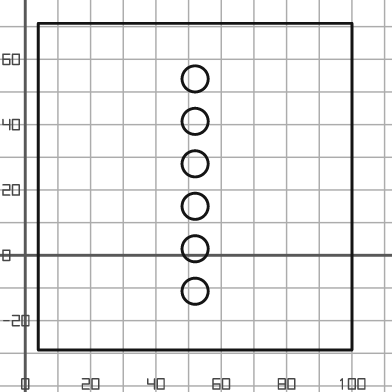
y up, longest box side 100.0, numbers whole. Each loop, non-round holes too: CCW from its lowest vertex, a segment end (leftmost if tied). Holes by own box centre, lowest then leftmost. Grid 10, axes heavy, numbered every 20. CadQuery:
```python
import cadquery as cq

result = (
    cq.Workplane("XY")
    .moveTo(4.0, -29.0)
    .lineTo(100.0, -29.0)
    .lineTo(100.0, 71.0)
    .lineTo(4.0, 71.0)
    .close()
    .moveTo(52.0, -11.0)
    .circle(4.0)
    .moveTo(52.0, 2.0)
    .circle(4.0)
    .moveTo(52.0, 15.0)
    .circle(4.0)
    .moveTo(52.0, 28.0)
    .circle(4.0)
    .moveTo(52.0, 41.0)
    .circle(4.0)
    .moveTo(52.0, 54.0)
    .circle(4.0)
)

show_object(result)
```